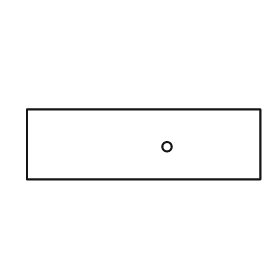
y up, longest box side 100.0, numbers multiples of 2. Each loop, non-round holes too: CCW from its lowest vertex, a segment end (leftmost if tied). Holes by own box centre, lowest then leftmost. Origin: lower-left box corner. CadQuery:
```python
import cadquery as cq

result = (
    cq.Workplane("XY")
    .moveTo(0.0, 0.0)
    .lineTo(100.0, 0.0)
    .lineTo(100.0, 30.0)
    .lineTo(0.0, 30.0)
    .close()
    .moveTo(60.0, 14.0)
    .circle(2.0)
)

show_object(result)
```